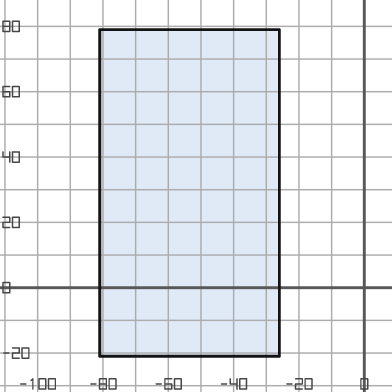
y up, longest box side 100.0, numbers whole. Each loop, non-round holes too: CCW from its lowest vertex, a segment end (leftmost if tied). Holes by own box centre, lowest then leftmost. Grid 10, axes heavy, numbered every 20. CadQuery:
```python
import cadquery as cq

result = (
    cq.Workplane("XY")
    .moveTo(-81.0, -21.0)
    .lineTo(-26.0, -21.0)
    .lineTo(-26.0, 79.0)
    .lineTo(-81.0, 79.0)
    .close()
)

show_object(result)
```